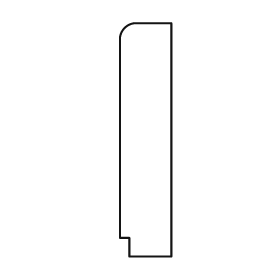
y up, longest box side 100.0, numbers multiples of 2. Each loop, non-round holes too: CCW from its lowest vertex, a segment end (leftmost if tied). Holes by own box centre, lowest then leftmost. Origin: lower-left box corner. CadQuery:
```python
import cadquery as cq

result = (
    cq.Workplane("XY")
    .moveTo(4.0, 0.0)
    .lineTo(22.0, 0.0)
    .lineTo(22.0, 100.0)
    .lineTo(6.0, 100.0)
    .threePointArc((2.0, 98.0), (0.0, 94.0))
    .lineTo(0.0, 8.0)
    .lineTo(4.0, 8.0)
    .close()
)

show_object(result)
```